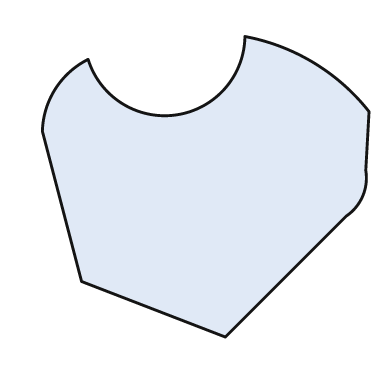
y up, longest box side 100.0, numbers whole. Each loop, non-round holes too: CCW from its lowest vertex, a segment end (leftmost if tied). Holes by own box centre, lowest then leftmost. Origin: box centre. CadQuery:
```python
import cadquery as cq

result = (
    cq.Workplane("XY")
    .moveTo(6.0, -46.0)
    .lineTo(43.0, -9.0)
    .threePointArc((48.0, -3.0), (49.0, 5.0))
    .lineTo(50.0, 23.0)
    .threePointArc((33.0, 38.0), (12.0, 46.0))
    .threePointArc((-9.0, 22.0), (-36.0, 39.0))
    .threePointArc((-46.0, 30.0), (-50.0, 17.0))
    .lineTo(-38.0, -29.0)
    .close()
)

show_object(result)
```